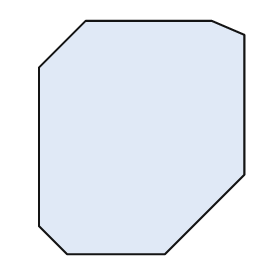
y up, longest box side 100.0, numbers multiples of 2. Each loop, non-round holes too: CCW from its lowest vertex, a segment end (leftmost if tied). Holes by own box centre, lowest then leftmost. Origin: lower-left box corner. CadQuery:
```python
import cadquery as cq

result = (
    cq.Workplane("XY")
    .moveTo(12.0, 0.0)
    .lineTo(54.0, 0.0)
    .lineTo(88.0, 34.0)
    .lineTo(88.0, 94.0)
    .lineTo(74.0, 100.0)
    .lineTo(20.0, 100.0)
    .lineTo(0.0, 80.0)
    .lineTo(0.0, 12.0)
    .close()
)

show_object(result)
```